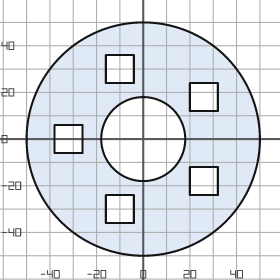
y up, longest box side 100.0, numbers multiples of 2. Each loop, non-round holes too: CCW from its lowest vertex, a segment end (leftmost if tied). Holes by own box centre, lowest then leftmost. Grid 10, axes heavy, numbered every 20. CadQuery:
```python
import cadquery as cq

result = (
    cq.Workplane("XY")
    .moveTo(0.0, 0.0)
    .circle(50.0)
    .moveTo(-16.0, -36.0)
    .lineTo(-4.0, -36.0)
    .lineTo(-4.0, -24.0)
    .lineTo(-16.0, -24.0)
    .close()
    .moveTo(20.0, -24.0)
    .lineTo(32.0, -24.0)
    .lineTo(32.0, -12.0)
    .lineTo(20.0, -12.0)
    .close()
    .moveTo(-38.0, -6.0)
    .lineTo(-26.0, -6.0)
    .lineTo(-26.0, 6.0)
    .lineTo(-38.0, 6.0)
    .close()
    .moveTo(0.0, 0.0)
    .circle(18.0)
    .moveTo(20.0, 12.0)
    .lineTo(32.0, 12.0)
    .lineTo(32.0, 24.0)
    .lineTo(20.0, 24.0)
    .close()
    .moveTo(-16.0, 24.0)
    .lineTo(-4.0, 24.0)
    .lineTo(-4.0, 36.0)
    .lineTo(-16.0, 36.0)
    .close()
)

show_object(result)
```